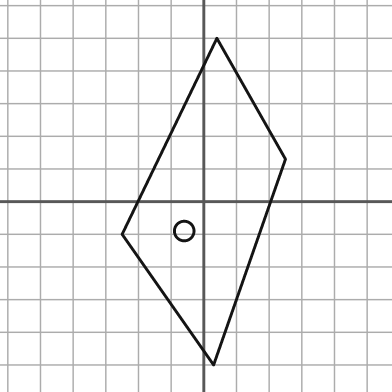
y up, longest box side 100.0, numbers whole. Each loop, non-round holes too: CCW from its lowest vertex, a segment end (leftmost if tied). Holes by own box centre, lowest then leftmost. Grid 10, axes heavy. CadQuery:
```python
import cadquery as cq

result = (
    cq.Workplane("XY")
    .moveTo(3.0, -50.0)
    .lineTo(25.0, 13.0)
    .lineTo(4.0, 50.0)
    .lineTo(-25.0, -10.0)
    .close()
    .moveTo(-6.0, -9.0)
    .circle(3.0)
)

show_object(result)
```